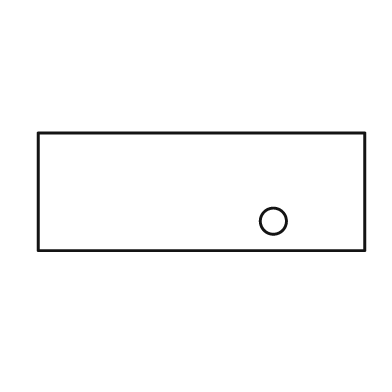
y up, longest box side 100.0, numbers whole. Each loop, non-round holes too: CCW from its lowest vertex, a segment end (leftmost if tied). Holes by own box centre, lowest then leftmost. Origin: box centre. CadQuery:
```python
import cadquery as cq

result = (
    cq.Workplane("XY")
    .moveTo(-50.0, -18.0)
    .lineTo(50.0, -18.0)
    .lineTo(50.0, 18.0)
    .lineTo(-50.0, 18.0)
    .close()
    .moveTo(22.0, -9.0)
    .circle(4.0)
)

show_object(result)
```